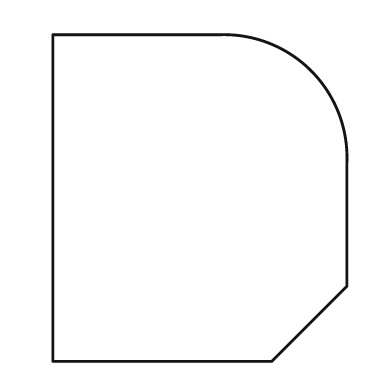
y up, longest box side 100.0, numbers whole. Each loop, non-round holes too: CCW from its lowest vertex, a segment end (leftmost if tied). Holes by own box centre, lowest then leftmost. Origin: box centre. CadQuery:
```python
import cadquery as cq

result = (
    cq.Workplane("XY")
    .moveTo(-45.0, -50.0)
    .lineTo(22.0, -50.0)
    .lineTo(45.0, -27.0)
    .lineTo(45.0, 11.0)
    .threePointArc((34.0, 39.0), (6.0, 50.0))
    .lineTo(-45.0, 50.0)
    .close()
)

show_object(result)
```